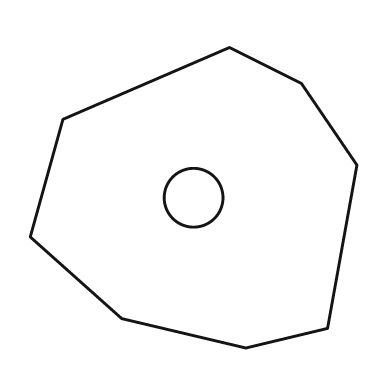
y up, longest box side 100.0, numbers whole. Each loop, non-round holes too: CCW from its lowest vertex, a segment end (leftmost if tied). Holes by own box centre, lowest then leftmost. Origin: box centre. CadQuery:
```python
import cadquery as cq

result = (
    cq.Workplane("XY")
    .moveTo(16.0, -46.0)
    .lineTo(41.0, -40.0)
    .lineTo(50.0, 10.0)
    .lineTo(33.0, 35.0)
    .lineTo(11.0, 46.0)
    .lineTo(-40.0, 24.0)
    .lineTo(-50.0, -12.0)
    .lineTo(-22.0, -37.0)
    .close()
    .moveTo(0.0, 0.0)
    .circle(9.0)
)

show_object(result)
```